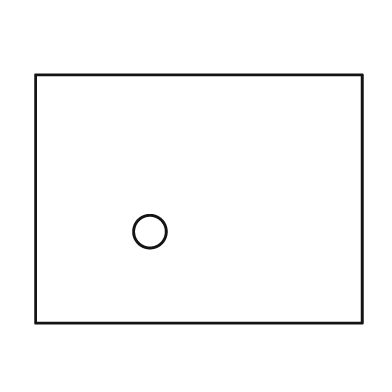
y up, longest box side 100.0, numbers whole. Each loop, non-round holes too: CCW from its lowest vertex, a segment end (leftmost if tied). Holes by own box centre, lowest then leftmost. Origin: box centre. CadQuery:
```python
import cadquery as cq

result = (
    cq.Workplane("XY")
    .moveTo(-50.0, -38.0)
    .lineTo(50.0, -38.0)
    .lineTo(50.0, 38.0)
    .lineTo(-50.0, 38.0)
    .close()
    .moveTo(-15.0, -10.0)
    .circle(5.0)
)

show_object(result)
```